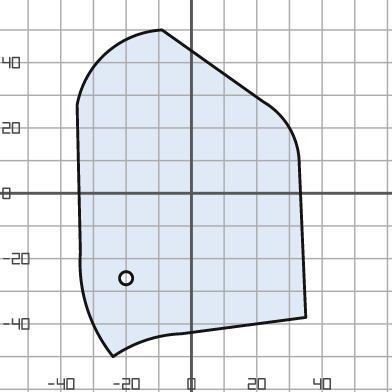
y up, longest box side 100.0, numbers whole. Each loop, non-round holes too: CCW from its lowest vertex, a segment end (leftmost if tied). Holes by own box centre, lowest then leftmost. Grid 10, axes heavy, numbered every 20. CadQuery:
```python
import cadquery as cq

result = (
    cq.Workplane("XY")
    .moveTo(-24.0, -50.0)
    .threePointArc((-14.0, -45.0), (-3.0, -43.0))
    .lineTo(35.0, -38.0)
    .lineTo(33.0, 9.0)
    .threePointArc((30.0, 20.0), (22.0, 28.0))
    .lineTo(-9.0, 50.0)
    .threePointArc((-26.0, 43.0), (-35.0, 27.0))
    .lineTo(-34.0, -18.0)
    .threePointArc((-32.0, -35.0), (-24.0, -50.0))
    .close()
    .moveTo(-20.0, -26.0)
    .circle(2.0)
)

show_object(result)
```